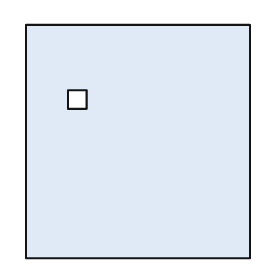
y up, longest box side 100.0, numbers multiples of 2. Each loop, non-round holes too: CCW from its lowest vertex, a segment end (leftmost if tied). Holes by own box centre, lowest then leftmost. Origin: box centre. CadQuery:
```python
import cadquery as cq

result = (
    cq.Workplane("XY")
    .moveTo(-48.0, -50.0)
    .lineTo(48.0, -50.0)
    .lineTo(48.0, 50.0)
    .lineTo(-48.0, 50.0)
    .close()
    .moveTo(-30.0, 14.0)
    .lineTo(-22.0, 14.0)
    .lineTo(-22.0, 22.0)
    .lineTo(-30.0, 22.0)
    .close()
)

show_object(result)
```